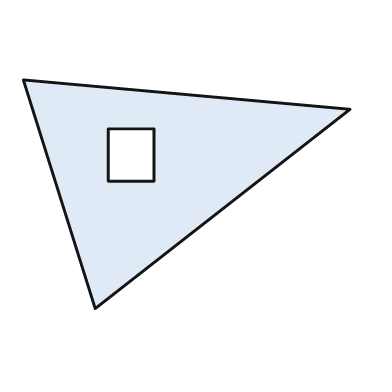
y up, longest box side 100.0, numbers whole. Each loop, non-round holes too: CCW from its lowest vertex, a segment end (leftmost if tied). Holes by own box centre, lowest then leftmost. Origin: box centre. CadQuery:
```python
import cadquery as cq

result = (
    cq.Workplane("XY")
    .moveTo(-28.0, -35.0)
    .lineTo(50.0, 26.0)
    .lineTo(-50.0, 35.0)
    .close()
    .moveTo(-24.0, 4.0)
    .lineTo(-10.0, 4.0)
    .lineTo(-10.0, 20.0)
    .lineTo(-24.0, 20.0)
    .close()
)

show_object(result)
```